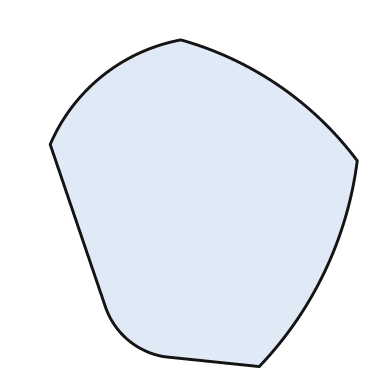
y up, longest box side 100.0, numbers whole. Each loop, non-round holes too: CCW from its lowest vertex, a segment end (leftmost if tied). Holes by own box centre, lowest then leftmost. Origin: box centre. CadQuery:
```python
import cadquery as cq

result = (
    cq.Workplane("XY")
    .moveTo(17.0, -50.0)
    .threePointArc((37.0, -21.0), (47.0, 13.0))
    .threePointArc((23.0, 36.0), (-7.0, 50.0))
    .threePointArc((-31.0, 39.0), (-47.0, 18.0))
    .lineTo(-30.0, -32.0)
    .threePointArc((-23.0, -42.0), (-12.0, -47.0))
    .close()
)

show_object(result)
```